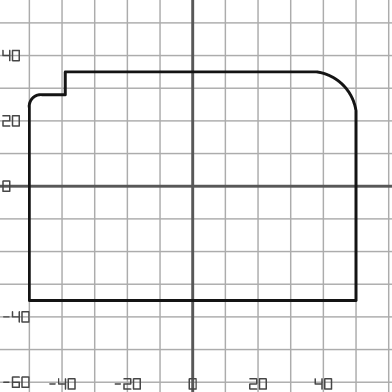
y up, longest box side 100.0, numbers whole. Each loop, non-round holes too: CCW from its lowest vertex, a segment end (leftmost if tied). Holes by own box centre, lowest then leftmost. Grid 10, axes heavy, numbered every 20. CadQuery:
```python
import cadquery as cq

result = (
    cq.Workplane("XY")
    .moveTo(-50.0, -35.0)
    .lineTo(50.0, -35.0)
    .lineTo(50.0, 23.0)
    .threePointArc((46.0, 31.0), (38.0, 35.0))
    .lineTo(-39.0, 35.0)
    .lineTo(-39.0, 28.0)
    .lineTo(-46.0, 28.0)
    .threePointArc((-49.0, 27.0), (-50.0, 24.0))
    .close()
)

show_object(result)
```